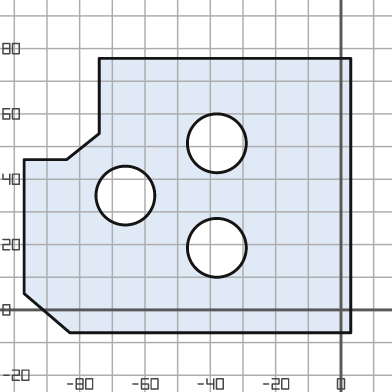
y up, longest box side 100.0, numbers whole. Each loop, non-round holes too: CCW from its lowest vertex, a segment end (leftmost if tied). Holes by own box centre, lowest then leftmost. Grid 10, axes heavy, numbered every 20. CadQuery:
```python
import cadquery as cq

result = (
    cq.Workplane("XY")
    .moveTo(-83.0, -7.0)
    .lineTo(3.0, -7.0)
    .lineTo(3.0, 77.0)
    .lineTo(-74.0, 77.0)
    .lineTo(-74.0, 54.0)
    .lineTo(-84.0, 46.0)
    .lineTo(-97.0, 46.0)
    .lineTo(-97.0, 5.0)
    .close()
    .moveTo(-38.0, 19.0)
    .circle(9.0)
    .moveTo(-66.0, 35.0)
    .circle(9.0)
    .moveTo(-38.0, 51.0)
    .circle(9.0)
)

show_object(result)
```